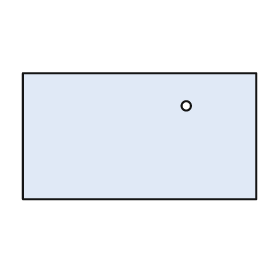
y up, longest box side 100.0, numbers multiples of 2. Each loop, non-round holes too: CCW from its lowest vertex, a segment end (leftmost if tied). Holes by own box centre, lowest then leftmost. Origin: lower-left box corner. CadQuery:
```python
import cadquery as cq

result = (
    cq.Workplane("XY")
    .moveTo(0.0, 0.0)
    .lineTo(100.0, 0.0)
    .lineTo(100.0, 54.0)
    .lineTo(0.0, 54.0)
    .close()
    .moveTo(70.0, 40.0)
    .circle(2.0)
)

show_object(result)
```